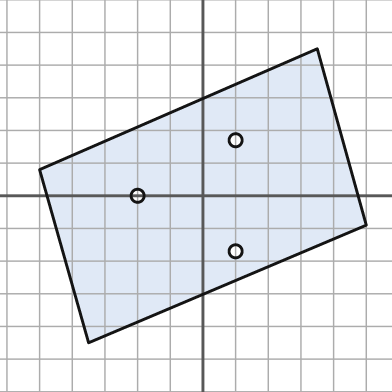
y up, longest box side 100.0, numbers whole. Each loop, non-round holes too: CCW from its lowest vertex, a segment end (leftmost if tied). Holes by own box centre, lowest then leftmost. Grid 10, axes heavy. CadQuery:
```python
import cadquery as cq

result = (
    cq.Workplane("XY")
    .moveTo(-35.0, -45.0)
    .lineTo(50.0, -9.0)
    .lineTo(35.0, 45.0)
    .lineTo(-50.0, 8.0)
    .close()
    .moveTo(10.0, -17.0)
    .circle(2.0)
    .moveTo(-20.0, 0.0)
    .circle(2.0)
    .moveTo(10.0, 17.0)
    .circle(2.0)
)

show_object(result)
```